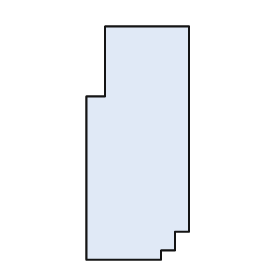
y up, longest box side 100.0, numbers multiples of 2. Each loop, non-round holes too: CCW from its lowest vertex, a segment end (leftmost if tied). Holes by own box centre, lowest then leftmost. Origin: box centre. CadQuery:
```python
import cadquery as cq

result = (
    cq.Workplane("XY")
    .moveTo(-22.0, -50.0)
    .lineTo(10.0, -50.0)
    .lineTo(10.0, -46.0)
    .lineTo(16.0, -46.0)
    .lineTo(16.0, -38.0)
    .lineTo(22.0, -38.0)
    .lineTo(22.0, 50.0)
    .lineTo(-14.0, 50.0)
    .lineTo(-14.0, 20.0)
    .lineTo(-22.0, 20.0)
    .close()
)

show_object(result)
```